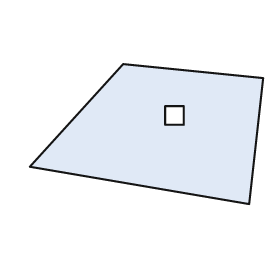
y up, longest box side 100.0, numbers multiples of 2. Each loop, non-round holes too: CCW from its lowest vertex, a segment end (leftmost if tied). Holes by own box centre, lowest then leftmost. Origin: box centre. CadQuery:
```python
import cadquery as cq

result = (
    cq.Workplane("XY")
    .moveTo(44.0, -30.0)
    .lineTo(50.0, 24.0)
    .lineTo(-10.0, 30.0)
    .lineTo(-50.0, -14.0)
    .close()
    .moveTo(8.0, 4.0)
    .lineTo(16.0, 4.0)
    .lineTo(16.0, 12.0)
    .lineTo(8.0, 12.0)
    .close()
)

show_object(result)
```